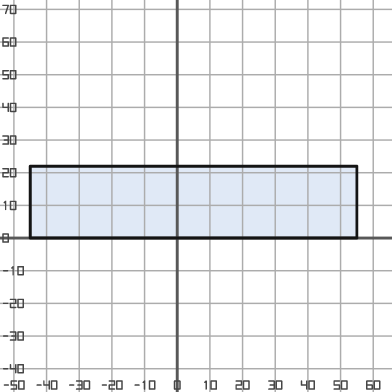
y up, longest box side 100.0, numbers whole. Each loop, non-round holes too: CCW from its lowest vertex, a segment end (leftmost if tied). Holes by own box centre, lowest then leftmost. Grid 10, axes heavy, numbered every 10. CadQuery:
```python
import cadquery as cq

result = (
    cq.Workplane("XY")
    .moveTo(-45.0, 0.0)
    .lineTo(55.0, 0.0)
    .lineTo(55.0, 22.0)
    .lineTo(-45.0, 22.0)
    .close()
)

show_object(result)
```